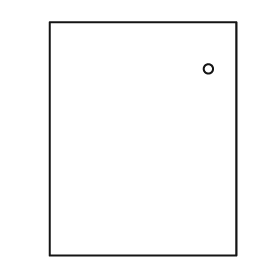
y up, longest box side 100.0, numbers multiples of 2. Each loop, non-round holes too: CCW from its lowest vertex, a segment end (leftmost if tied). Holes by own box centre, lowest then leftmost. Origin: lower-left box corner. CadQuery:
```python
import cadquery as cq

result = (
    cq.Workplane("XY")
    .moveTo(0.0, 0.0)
    .lineTo(80.0, 0.0)
    .lineTo(80.0, 100.0)
    .lineTo(0.0, 100.0)
    .close()
    .moveTo(68.0, 80.0)
    .circle(2.0)
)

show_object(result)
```